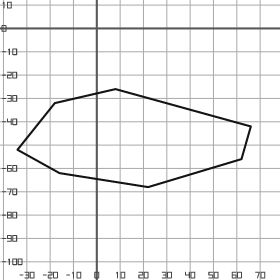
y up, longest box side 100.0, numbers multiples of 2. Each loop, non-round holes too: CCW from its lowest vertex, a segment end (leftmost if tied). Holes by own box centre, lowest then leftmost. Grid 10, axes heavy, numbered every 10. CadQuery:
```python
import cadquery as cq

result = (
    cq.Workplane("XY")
    .moveTo(22.0, -68.0)
    .lineTo(62.0, -56.0)
    .lineTo(66.0, -42.0)
    .lineTo(8.0, -26.0)
    .lineTo(-18.0, -32.0)
    .lineTo(-34.0, -52.0)
    .lineTo(-16.0, -62.0)
    .close()
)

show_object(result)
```